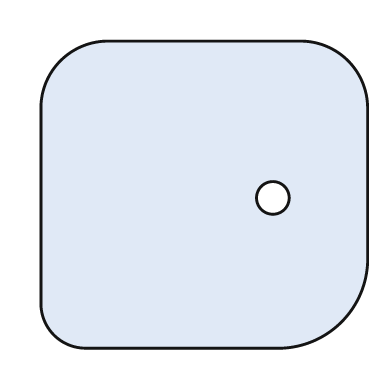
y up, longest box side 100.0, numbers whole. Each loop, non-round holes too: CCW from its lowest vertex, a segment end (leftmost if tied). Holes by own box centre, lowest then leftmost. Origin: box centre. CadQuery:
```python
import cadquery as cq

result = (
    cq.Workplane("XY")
    .moveTo(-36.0, -47.0)
    .lineTo(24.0, -47.0)
    .threePointArc((42.0, -39.0), (50.0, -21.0))
    .lineTo(50.0, 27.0)
    .threePointArc((44.0, 41.0), (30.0, 47.0))
    .lineTo(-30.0, 47.0)
    .threePointArc((-44.0, 41.0), (-50.0, 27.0))
    .lineTo(-50.0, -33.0)
    .threePointArc((-46.0, -43.0), (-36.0, -47.0))
    .close()
    .moveTo(21.0, -1.0)
    .circle(5.0)
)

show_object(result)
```